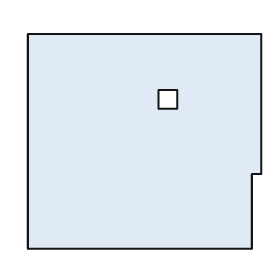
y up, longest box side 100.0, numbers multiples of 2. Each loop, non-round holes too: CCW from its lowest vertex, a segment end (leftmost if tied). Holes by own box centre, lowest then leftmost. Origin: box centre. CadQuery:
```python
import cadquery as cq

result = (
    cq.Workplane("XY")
    .moveTo(-50.0, -46.0)
    .lineTo(46.0, -46.0)
    .lineTo(46.0, -14.0)
    .lineTo(50.0, -14.0)
    .lineTo(50.0, 46.0)
    .lineTo(-50.0, 46.0)
    .close()
    .moveTo(6.0, 14.0)
    .lineTo(14.0, 14.0)
    .lineTo(14.0, 22.0)
    .lineTo(6.0, 22.0)
    .close()
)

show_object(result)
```